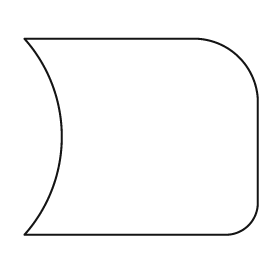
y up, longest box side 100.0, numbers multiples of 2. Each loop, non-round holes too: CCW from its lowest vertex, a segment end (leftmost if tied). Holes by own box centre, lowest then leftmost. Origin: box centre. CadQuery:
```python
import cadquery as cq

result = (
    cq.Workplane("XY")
    .moveTo(-50.0, -42.0)
    .lineTo(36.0, -42.0)
    .threePointArc((46.0, -38.0), (50.0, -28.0))
    .lineTo(50.0, 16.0)
    .threePointArc((42.0, 34.0), (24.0, 42.0))
    .lineTo(-50.0, 42.0)
    .threePointArc((-34.0, 0.0), (-50.0, -42.0))
    .close()
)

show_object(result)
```